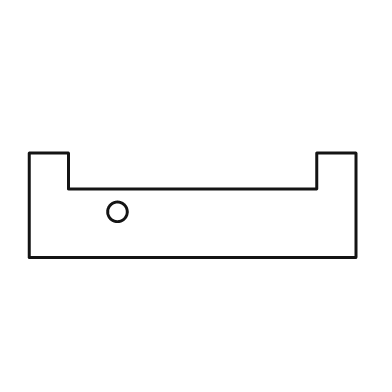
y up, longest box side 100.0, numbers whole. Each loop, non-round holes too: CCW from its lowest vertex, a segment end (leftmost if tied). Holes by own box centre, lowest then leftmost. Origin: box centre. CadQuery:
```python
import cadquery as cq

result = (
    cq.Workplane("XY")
    .moveTo(-50.0, -16.0)
    .lineTo(50.0, -16.0)
    .lineTo(50.0, 16.0)
    .lineTo(38.0, 16.0)
    .lineTo(38.0, 5.0)
    .lineTo(-38.0, 5.0)
    .lineTo(-38.0, 16.0)
    .lineTo(-50.0, 16.0)
    .close()
    .moveTo(-23.0, -2.0)
    .circle(3.0)
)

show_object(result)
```